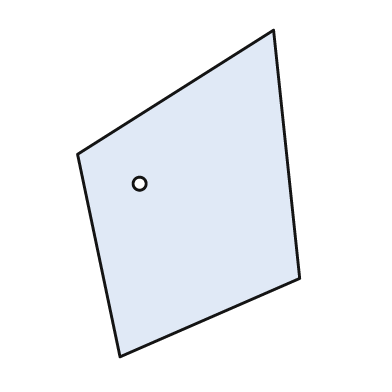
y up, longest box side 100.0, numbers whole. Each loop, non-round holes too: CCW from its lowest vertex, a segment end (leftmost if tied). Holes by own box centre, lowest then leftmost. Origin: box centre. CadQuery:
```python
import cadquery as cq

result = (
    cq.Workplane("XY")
    .moveTo(-21.0, -50.0)
    .lineTo(34.0, -26.0)
    .lineTo(26.0, 50.0)
    .lineTo(-34.0, 12.0)
    .close()
    .moveTo(-15.0, 3.0)
    .circle(2.0)
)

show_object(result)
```